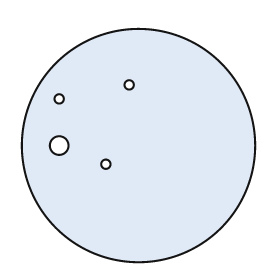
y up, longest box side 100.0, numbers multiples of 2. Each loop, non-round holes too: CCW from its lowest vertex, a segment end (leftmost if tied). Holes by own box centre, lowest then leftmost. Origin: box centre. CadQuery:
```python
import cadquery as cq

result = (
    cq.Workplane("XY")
    .moveTo(0.0, 0.0)
    .circle(50.0)
    .moveTo(-14.0, -8.0)
    .circle(2.0)
    .moveTo(-34.0, 0.0)
    .circle(4.0)
    .moveTo(-34.0, 20.0)
    .circle(2.0)
    .moveTo(-4.0, 26.0)
    .circle(2.0)
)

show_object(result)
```